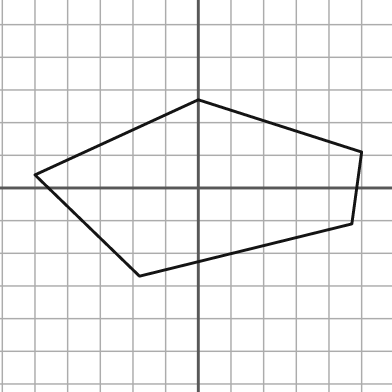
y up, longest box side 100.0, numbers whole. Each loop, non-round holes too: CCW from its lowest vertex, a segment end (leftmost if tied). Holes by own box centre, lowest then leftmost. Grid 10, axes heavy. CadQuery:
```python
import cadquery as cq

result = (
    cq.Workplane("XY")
    .moveTo(-18.0, -27.0)
    .lineTo(47.0, -11.0)
    .lineTo(50.0, 11.0)
    .lineTo(0.0, 27.0)
    .lineTo(-50.0, 4.0)
    .close()
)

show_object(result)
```